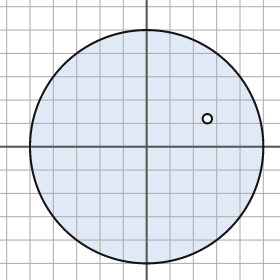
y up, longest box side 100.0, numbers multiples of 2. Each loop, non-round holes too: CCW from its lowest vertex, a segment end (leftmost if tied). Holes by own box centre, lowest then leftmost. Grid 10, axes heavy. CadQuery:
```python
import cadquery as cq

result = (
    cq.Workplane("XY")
    .moveTo(0.0, 0.0)
    .circle(50.0)
    .moveTo(26.0, 12.0)
    .circle(2.0)
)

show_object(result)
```